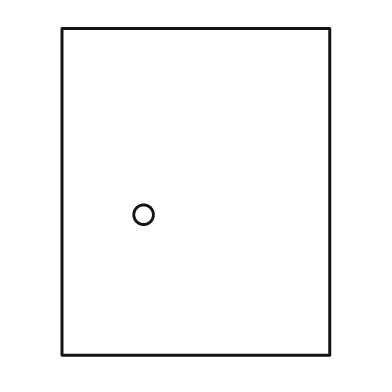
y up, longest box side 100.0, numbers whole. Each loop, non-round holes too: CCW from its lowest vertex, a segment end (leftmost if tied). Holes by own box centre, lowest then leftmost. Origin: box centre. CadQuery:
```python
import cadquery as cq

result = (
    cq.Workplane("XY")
    .moveTo(-41.0, -50.0)
    .lineTo(41.0, -50.0)
    .lineTo(41.0, 50.0)
    .lineTo(-41.0, 50.0)
    .close()
    .moveTo(-16.0, -7.0)
    .circle(3.0)
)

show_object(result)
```